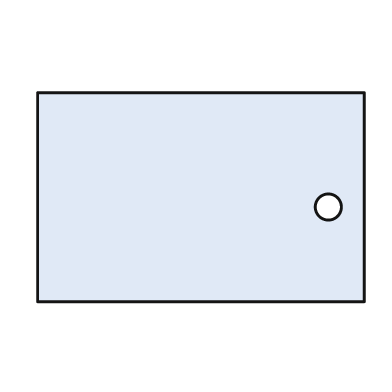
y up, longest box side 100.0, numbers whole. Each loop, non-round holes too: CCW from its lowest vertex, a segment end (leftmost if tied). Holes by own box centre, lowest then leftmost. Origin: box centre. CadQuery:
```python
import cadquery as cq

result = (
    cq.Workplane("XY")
    .moveTo(-50.0, -32.0)
    .lineTo(50.0, -32.0)
    .lineTo(50.0, 32.0)
    .lineTo(-50.0, 32.0)
    .close()
    .moveTo(39.0, -3.0)
    .circle(4.0)
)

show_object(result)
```